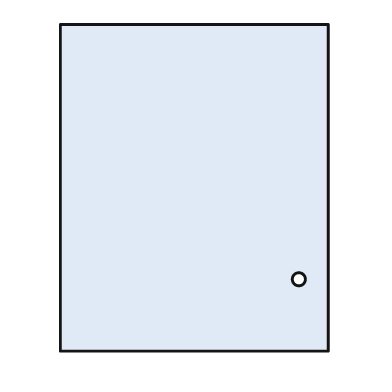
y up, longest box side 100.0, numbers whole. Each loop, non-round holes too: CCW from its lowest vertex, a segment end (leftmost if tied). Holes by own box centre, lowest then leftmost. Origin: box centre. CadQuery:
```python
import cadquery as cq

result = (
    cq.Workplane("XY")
    .moveTo(-41.0, -50.0)
    .lineTo(41.0, -50.0)
    .lineTo(41.0, 50.0)
    .lineTo(-41.0, 50.0)
    .close()
    .moveTo(32.0, -28.0)
    .circle(2.0)
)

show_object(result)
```